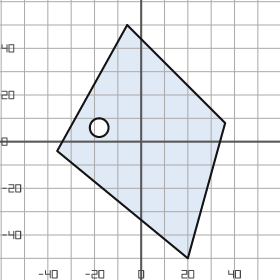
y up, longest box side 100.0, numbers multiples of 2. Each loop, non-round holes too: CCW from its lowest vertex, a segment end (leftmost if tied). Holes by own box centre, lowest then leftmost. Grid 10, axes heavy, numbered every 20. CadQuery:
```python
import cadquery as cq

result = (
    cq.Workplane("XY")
    .moveTo(20.0, -50.0)
    .lineTo(36.0, 8.0)
    .lineTo(-6.0, 50.0)
    .lineTo(-36.0, -4.0)
    .close()
    .moveTo(-18.0, 6.0)
    .circle(4.0)
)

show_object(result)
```